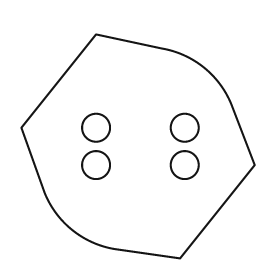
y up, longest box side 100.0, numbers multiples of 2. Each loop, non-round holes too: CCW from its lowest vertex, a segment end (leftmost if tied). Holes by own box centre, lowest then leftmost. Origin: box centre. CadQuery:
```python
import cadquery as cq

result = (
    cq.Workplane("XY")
    .moveTo(18.0, -48.0)
    .lineTo(50.0, -8.0)
    .lineTo(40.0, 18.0)
    .threePointArc((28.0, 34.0), (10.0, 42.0))
    .lineTo(-18.0, 48.0)
    .lineTo(-50.0, 8.0)
    .lineTo(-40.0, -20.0)
    .threePointArc((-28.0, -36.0), (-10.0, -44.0))
    .close()
    .moveTo(-18.0, -8.0)
    .circle(6.0)
    .moveTo(20.0, -8.0)
    .circle(6.0)
    .moveTo(-18.0, 8.0)
    .circle(6.0)
    .moveTo(20.0, 8.0)
    .circle(6.0)
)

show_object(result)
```